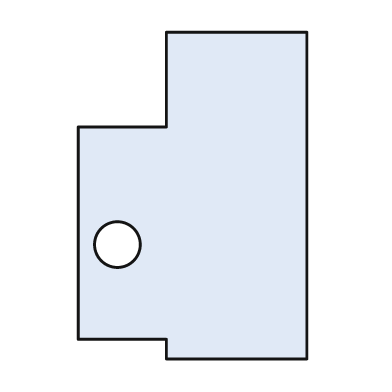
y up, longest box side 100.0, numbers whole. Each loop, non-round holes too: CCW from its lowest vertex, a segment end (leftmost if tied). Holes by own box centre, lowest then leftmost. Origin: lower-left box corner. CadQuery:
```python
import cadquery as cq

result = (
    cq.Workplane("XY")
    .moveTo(27.0, 0.0)
    .lineTo(70.0, 0.0)
    .lineTo(70.0, 100.0)
    .lineTo(27.0, 100.0)
    .lineTo(27.0, 71.0)
    .lineTo(0.0, 71.0)
    .lineTo(0.0, 6.0)
    .lineTo(27.0, 6.0)
    .close()
    .moveTo(12.0, 35.0)
    .circle(7.0)
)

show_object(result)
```